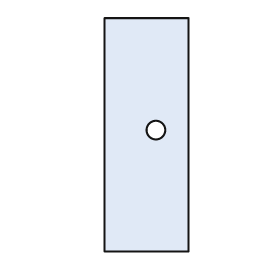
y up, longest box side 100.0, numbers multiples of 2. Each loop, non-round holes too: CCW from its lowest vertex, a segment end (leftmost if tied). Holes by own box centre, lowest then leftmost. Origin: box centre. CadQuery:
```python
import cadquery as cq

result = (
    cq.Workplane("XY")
    .moveTo(-18.0, -50.0)
    .lineTo(18.0, -50.0)
    .lineTo(18.0, 50.0)
    .lineTo(-18.0, 50.0)
    .close()
    .moveTo(4.0, 2.0)
    .circle(4.0)
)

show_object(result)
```